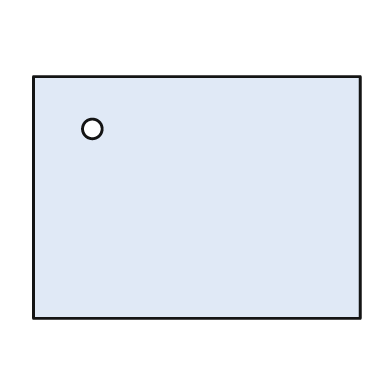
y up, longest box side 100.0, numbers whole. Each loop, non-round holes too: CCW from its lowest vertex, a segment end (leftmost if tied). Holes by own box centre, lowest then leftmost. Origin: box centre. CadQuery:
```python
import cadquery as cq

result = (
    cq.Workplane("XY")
    .moveTo(-50.0, -37.0)
    .lineTo(50.0, -37.0)
    .lineTo(50.0, 37.0)
    .lineTo(-50.0, 37.0)
    .close()
    .moveTo(-32.0, 21.0)
    .circle(3.0)
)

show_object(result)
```